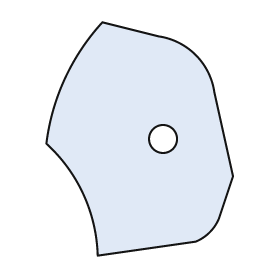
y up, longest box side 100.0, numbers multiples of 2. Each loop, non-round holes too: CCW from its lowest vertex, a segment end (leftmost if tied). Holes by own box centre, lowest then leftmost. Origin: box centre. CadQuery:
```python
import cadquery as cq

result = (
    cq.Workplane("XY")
    .moveTo(-18.0, -50.0)
    .lineTo(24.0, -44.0)
    .threePointArc((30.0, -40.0), (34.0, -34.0))
    .lineTo(40.0, -16.0)
    .lineTo(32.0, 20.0)
    .threePointArc((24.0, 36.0), (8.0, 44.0))
    .lineTo(-16.0, 50.0)
    .threePointArc((-32.0, 26.0), (-40.0, -2.0))
    .threePointArc((-24.0, -24.0), (-18.0, -50.0))
    .close()
    .moveTo(10.0, 0.0)
    .circle(6.0)
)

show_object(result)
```